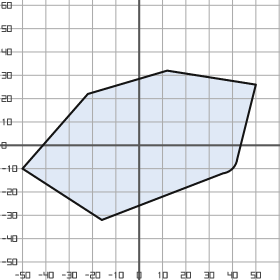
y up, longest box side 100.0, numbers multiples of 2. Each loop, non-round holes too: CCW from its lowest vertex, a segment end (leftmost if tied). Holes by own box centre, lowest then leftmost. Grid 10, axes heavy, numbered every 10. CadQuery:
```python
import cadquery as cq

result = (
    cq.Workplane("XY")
    .moveTo(-16.0, -32.0)
    .lineTo(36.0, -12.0)
    .threePointArc((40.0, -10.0), (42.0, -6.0))
    .lineTo(50.0, 26.0)
    .lineTo(12.0, 32.0)
    .lineTo(-22.0, 22.0)
    .lineTo(-50.0, -10.0)
    .close()
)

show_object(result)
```